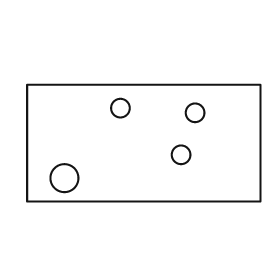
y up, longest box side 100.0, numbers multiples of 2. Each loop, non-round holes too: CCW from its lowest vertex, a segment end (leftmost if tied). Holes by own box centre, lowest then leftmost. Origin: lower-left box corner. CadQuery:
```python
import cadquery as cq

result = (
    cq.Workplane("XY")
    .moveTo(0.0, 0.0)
    .lineTo(100.0, 0.0)
    .lineTo(100.0, 50.0)
    .lineTo(0.0, 50.0)
    .close()
    .moveTo(16.0, 10.0)
    .circle(6.0)
    .moveTo(66.0, 20.0)
    .circle(4.0)
    .moveTo(72.0, 38.0)
    .circle(4.0)
    .moveTo(40.0, 40.0)
    .circle(4.0)
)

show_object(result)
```